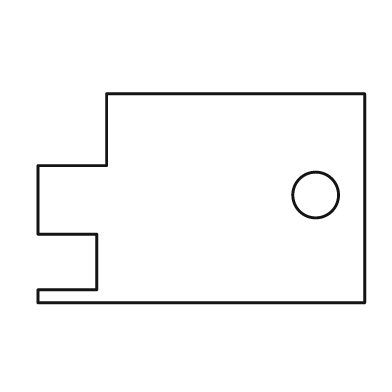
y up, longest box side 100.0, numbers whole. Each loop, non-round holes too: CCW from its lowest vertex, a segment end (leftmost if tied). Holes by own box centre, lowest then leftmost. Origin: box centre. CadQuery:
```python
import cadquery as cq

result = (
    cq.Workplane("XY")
    .moveTo(-50.0, -32.0)
    .lineTo(50.0, -32.0)
    .lineTo(50.0, 32.0)
    .lineTo(-29.0, 32.0)
    .lineTo(-29.0, 10.0)
    .lineTo(-50.0, 10.0)
    .lineTo(-50.0, -11.0)
    .lineTo(-32.0, -11.0)
    .lineTo(-32.0, -28.0)
    .lineTo(-50.0, -28.0)
    .close()
    .moveTo(35.0, 1.0)
    .circle(7.0)
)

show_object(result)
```